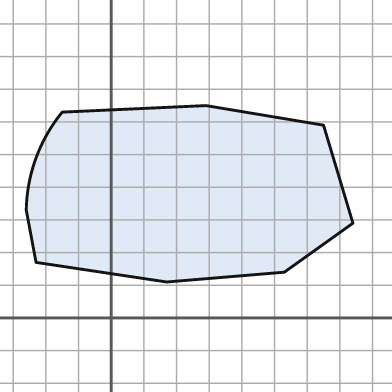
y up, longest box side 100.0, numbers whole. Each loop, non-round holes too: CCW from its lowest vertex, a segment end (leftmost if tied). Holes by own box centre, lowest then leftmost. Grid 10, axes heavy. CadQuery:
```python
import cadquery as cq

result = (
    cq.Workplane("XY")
    .moveTo(17.0, 11.0)
    .lineTo(53.0, 14.0)
    .lineTo(74.0, 29.0)
    .lineTo(65.0, 59.0)
    .lineTo(29.0, 65.0)
    .lineTo(-15.0, 63.0)
    .threePointArc((-23.0, 49.0), (-26.0, 33.0))
    .lineTo(-23.0, 17.0)
    .close()
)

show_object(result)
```